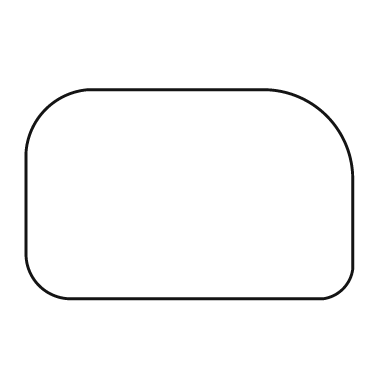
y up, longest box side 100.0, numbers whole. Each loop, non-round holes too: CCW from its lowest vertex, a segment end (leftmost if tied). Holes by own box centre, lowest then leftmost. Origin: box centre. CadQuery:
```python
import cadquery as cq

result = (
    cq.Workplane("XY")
    .moveTo(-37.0, -32.0)
    .lineTo(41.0, -32.0)
    .threePointArc((47.0, -29.0), (50.0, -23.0))
    .lineTo(50.0, 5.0)
    .threePointArc((42.0, 24.0), (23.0, 32.0))
    .lineTo(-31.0, 32.0)
    .threePointArc((-44.0, 26.0), (-50.0, 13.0))
    .lineTo(-50.0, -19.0)
    .threePointArc((-46.0, -28.0), (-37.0, -32.0))
    .close()
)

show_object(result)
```